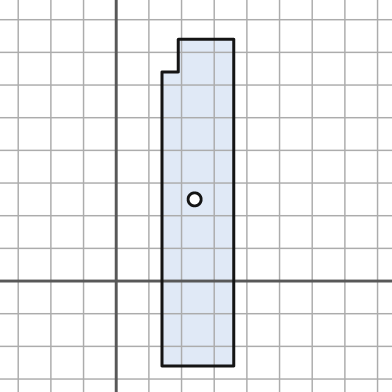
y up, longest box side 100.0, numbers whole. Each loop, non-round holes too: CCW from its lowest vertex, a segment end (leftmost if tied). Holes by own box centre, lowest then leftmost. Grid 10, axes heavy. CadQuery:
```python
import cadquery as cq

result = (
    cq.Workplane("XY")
    .moveTo(14.0, -26.0)
    .lineTo(36.0, -26.0)
    .lineTo(36.0, 74.0)
    .lineTo(19.0, 74.0)
    .lineTo(19.0, 64.0)
    .lineTo(14.0, 64.0)
    .close()
    .moveTo(24.0, 25.0)
    .circle(2.0)
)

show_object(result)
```